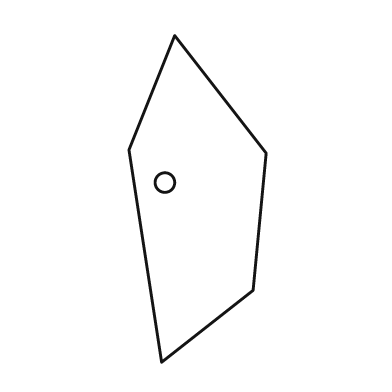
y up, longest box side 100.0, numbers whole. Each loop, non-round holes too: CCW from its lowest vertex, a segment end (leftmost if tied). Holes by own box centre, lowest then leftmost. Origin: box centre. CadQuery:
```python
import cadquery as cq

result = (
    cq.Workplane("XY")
    .moveTo(-11.0, -50.0)
    .lineTo(17.0, -28.0)
    .lineTo(21.0, 14.0)
    .lineTo(-7.0, 50.0)
    .lineTo(-21.0, 15.0)
    .close()
    .moveTo(-10.0, 5.0)
    .circle(3.0)
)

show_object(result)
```